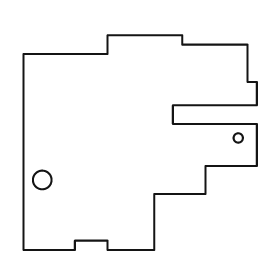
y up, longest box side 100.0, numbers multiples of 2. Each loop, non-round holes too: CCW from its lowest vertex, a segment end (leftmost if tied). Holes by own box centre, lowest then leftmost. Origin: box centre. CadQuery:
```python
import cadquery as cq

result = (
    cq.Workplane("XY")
    .moveTo(-50.0, -46.0)
    .lineTo(-28.0, -46.0)
    .lineTo(-28.0, -42.0)
    .lineTo(-14.0, -42.0)
    .lineTo(-14.0, -46.0)
    .lineTo(6.0, -46.0)
    .lineTo(6.0, -22.0)
    .lineTo(28.0, -22.0)
    .lineTo(28.0, -10.0)
    .lineTo(50.0, -10.0)
    .lineTo(50.0, 8.0)
    .lineTo(14.0, 8.0)
    .lineTo(14.0, 16.0)
    .lineTo(50.0, 16.0)
    .lineTo(50.0, 26.0)
    .lineTo(46.0, 26.0)
    .lineTo(46.0, 42.0)
    .lineTo(18.0, 42.0)
    .lineTo(18.0, 46.0)
    .lineTo(-14.0, 46.0)
    .lineTo(-14.0, 38.0)
    .lineTo(-50.0, 38.0)
    .close()
    .moveTo(-42.0, -16.0)
    .circle(4.0)
    .moveTo(42.0, 2.0)
    .circle(2.0)
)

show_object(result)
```